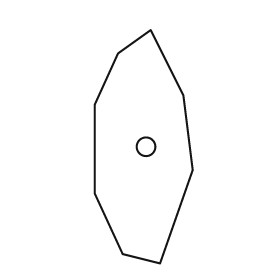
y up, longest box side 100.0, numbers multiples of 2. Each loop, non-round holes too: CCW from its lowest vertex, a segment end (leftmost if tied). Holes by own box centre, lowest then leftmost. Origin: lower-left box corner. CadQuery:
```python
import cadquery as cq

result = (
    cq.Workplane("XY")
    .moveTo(28.0, 0.0)
    .lineTo(42.0, 40.0)
    .lineTo(38.0, 72.0)
    .lineTo(24.0, 100.0)
    .lineTo(10.0, 90.0)
    .lineTo(0.0, 68.0)
    .lineTo(0.0, 30.0)
    .lineTo(12.0, 4.0)
    .close()
    .moveTo(22.0, 50.0)
    .circle(4.0)
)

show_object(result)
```